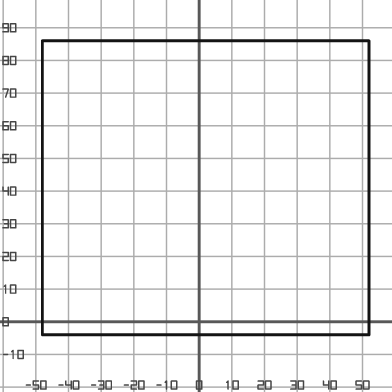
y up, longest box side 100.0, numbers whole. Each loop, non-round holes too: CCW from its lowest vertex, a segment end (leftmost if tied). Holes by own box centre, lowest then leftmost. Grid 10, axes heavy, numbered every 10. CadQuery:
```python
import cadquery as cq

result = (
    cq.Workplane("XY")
    .moveTo(-48.0, -4.0)
    .lineTo(52.0, -4.0)
    .lineTo(52.0, 86.0)
    .lineTo(-48.0, 86.0)
    .close()
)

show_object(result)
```